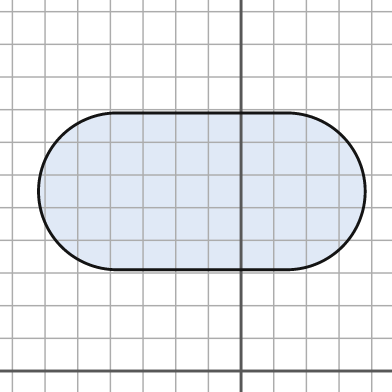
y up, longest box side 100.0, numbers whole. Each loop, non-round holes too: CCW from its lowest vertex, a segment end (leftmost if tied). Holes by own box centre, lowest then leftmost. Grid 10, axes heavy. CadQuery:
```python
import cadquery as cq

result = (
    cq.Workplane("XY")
    .moveTo(-38.0, 31.0)
    .lineTo(14.0, 31.0)
    .threePointArc((38.0, 55.0), (14.0, 79.0))
    .lineTo(-38.0, 79.0)
    .threePointArc((-62.0, 55.0), (-38.0, 31.0))
    .close()
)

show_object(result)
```